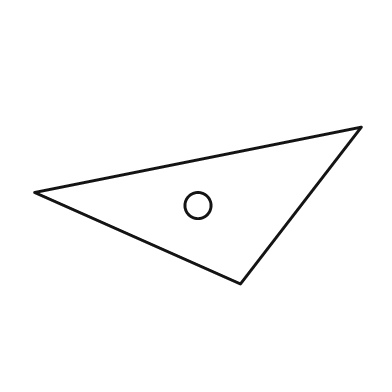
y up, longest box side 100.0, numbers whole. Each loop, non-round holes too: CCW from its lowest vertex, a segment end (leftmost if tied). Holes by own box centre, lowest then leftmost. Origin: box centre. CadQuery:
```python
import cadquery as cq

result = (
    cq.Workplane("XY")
    .moveTo(13.0, -24.0)
    .lineTo(50.0, 24.0)
    .lineTo(-50.0, 4.0)
    .close()
    .moveTo(0.0, 0.0)
    .circle(4.0)
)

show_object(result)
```